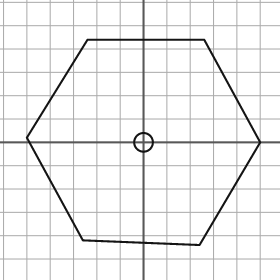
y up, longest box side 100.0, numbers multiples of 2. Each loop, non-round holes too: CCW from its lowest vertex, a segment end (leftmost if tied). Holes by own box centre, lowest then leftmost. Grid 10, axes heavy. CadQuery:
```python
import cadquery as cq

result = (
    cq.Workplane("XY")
    .moveTo(24.0, -44.0)
    .lineTo(50.0, 0.0)
    .lineTo(26.0, 44.0)
    .lineTo(-24.0, 44.0)
    .lineTo(-50.0, 2.0)
    .lineTo(-26.0, -42.0)
    .close()
    .moveTo(0.0, 0.0)
    .circle(4.0)
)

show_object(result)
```